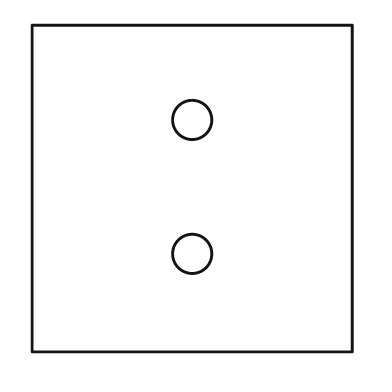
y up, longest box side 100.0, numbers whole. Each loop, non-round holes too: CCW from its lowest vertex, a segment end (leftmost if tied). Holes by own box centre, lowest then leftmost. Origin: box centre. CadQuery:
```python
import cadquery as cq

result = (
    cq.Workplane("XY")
    .moveTo(-49.0, -50.0)
    .lineTo(49.0, -50.0)
    .lineTo(49.0, 50.0)
    .lineTo(-49.0, 50.0)
    .close()
    .moveTo(0.0, -20.0)
    .circle(6.0)
    .moveTo(0.0, 21.0)
    .circle(6.0)
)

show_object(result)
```